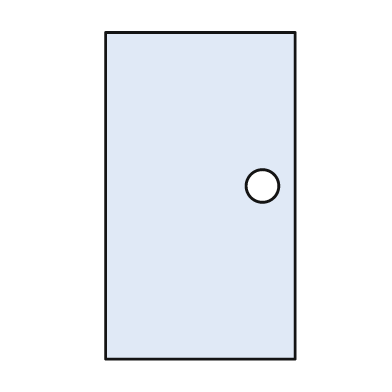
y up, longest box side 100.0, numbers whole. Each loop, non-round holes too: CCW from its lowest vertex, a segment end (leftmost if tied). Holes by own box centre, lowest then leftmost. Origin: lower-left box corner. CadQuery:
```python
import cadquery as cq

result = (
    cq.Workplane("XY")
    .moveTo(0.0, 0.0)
    .lineTo(58.0, 0.0)
    .lineTo(58.0, 100.0)
    .lineTo(0.0, 100.0)
    .close()
    .moveTo(48.0, 53.0)
    .circle(5.0)
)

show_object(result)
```